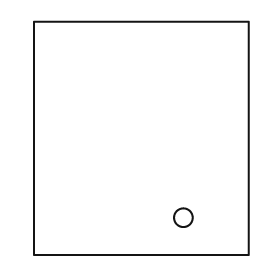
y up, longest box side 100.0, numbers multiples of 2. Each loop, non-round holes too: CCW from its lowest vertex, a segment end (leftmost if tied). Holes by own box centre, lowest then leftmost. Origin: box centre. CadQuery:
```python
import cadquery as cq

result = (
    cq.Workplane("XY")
    .moveTo(-46.0, -50.0)
    .lineTo(46.0, -50.0)
    .lineTo(46.0, 50.0)
    .lineTo(-46.0, 50.0)
    .close()
    .moveTo(18.0, -34.0)
    .circle(4.0)
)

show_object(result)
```